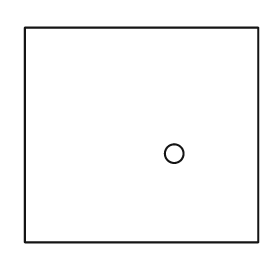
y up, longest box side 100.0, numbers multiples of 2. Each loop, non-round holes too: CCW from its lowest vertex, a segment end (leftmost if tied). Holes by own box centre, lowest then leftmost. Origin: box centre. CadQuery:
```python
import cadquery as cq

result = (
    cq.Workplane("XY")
    .moveTo(-50.0, -46.0)
    .lineTo(50.0, -46.0)
    .lineTo(50.0, 46.0)
    .lineTo(-50.0, 46.0)
    .close()
    .moveTo(14.0, -8.0)
    .circle(4.0)
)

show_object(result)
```